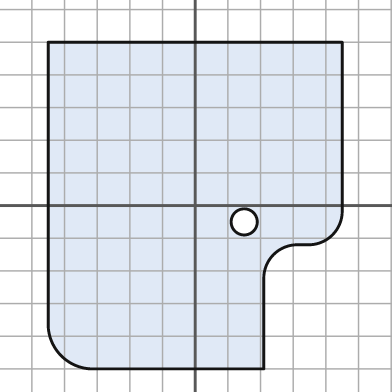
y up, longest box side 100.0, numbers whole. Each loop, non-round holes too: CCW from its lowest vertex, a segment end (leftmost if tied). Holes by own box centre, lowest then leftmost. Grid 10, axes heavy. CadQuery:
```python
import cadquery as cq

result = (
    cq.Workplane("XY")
    .moveTo(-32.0, -50.0)
    .lineTo(21.0, -50.0)
    .lineTo(21.0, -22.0)
    .threePointArc((24.0, -15.0), (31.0, -12.0))
    .lineTo(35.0, -12.0)
    .threePointArc((42.0, -9.0), (45.0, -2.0))
    .lineTo(45.0, 50.0)
    .lineTo(-45.0, 50.0)
    .lineTo(-45.0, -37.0)
    .threePointArc((-41.0, -46.0), (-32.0, -50.0))
    .close()
    .moveTo(15.0, -5.0)
    .circle(4.0)
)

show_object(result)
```